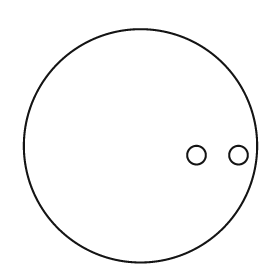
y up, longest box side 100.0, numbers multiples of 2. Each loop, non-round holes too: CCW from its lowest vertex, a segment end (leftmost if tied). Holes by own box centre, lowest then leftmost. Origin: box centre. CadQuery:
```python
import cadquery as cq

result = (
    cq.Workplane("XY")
    .moveTo(0.0, 0.0)
    .circle(50.0)
    .moveTo(24.0, -4.0)
    .circle(4.0)
    .moveTo(42.0, -4.0)
    .circle(4.0)
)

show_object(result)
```